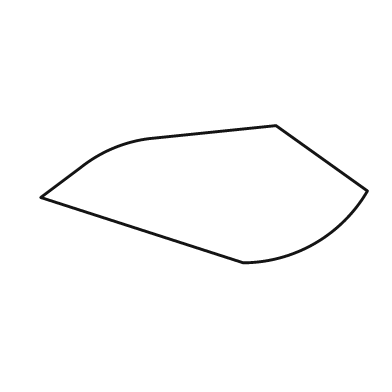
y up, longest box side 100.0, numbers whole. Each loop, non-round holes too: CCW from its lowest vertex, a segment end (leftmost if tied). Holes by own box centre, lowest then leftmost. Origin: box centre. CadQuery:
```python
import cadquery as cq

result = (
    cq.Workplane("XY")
    .moveTo(12.0, -21.0)
    .threePointArc((34.0, -15.0), (50.0, 1.0))
    .lineTo(22.0, 21.0)
    .lineTo(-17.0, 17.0)
    .threePointArc((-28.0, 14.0), (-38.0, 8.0))
    .lineTo(-50.0, -1.0)
    .close()
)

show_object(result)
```